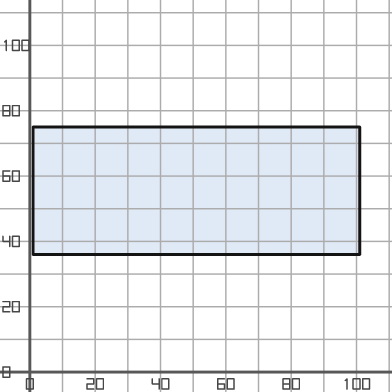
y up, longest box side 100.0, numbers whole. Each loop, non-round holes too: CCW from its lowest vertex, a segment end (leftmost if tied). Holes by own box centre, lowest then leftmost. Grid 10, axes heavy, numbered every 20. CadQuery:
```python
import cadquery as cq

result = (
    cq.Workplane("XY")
    .moveTo(1.0, 36.0)
    .lineTo(101.0, 36.0)
    .lineTo(101.0, 75.0)
    .lineTo(1.0, 75.0)
    .close()
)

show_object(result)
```